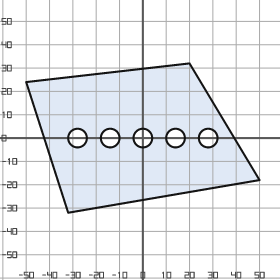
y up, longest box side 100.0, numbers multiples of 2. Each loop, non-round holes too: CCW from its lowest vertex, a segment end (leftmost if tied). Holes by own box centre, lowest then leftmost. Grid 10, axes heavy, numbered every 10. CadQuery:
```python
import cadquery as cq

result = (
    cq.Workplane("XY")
    .moveTo(-32.0, -32.0)
    .lineTo(50.0, -18.0)
    .lineTo(20.0, 32.0)
    .lineTo(-50.0, 24.0)
    .close()
    .moveTo(-28.0, 0.0)
    .circle(4.0)
    .moveTo(-14.0, 0.0)
    .circle(4.0)
    .moveTo(0.0, 0.0)
    .circle(4.0)
    .moveTo(14.0, 0.0)
    .circle(4.0)
    .moveTo(28.0, 0.0)
    .circle(4.0)
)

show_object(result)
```